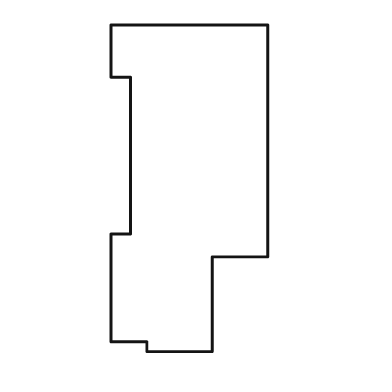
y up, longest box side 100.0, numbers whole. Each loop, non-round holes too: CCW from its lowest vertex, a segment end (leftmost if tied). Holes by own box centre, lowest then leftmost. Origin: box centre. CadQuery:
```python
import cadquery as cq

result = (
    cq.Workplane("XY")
    .moveTo(-13.0, -50.0)
    .lineTo(7.0, -50.0)
    .lineTo(7.0, -21.0)
    .lineTo(24.0, -21.0)
    .lineTo(24.0, 50.0)
    .lineTo(-24.0, 50.0)
    .lineTo(-24.0, 34.0)
    .lineTo(-18.0, 34.0)
    .lineTo(-18.0, -14.0)
    .lineTo(-24.0, -14.0)
    .lineTo(-24.0, -47.0)
    .lineTo(-13.0, -47.0)
    .close()
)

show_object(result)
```